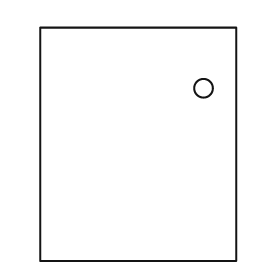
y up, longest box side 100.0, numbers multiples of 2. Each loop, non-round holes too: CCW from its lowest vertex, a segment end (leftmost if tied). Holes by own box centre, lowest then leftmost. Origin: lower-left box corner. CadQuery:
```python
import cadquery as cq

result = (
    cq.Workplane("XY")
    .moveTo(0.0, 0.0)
    .lineTo(84.0, 0.0)
    .lineTo(84.0, 100.0)
    .lineTo(0.0, 100.0)
    .close()
    .moveTo(70.0, 74.0)
    .circle(4.0)
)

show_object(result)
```